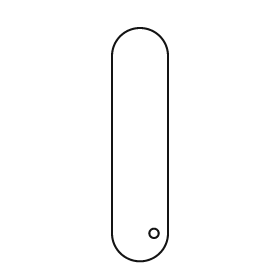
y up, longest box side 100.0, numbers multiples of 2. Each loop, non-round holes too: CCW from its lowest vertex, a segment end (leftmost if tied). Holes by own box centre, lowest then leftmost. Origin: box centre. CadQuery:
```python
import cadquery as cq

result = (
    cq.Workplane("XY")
    .moveTo(-12.0, -38.0)
    .threePointArc((0.0, -50.0), (12.0, -38.0))
    .lineTo(12.0, 38.0)
    .threePointArc((0.0, 50.0), (-12.0, 38.0))
    .close()
    .moveTo(6.0, -38.0)
    .circle(2.0)
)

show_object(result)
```